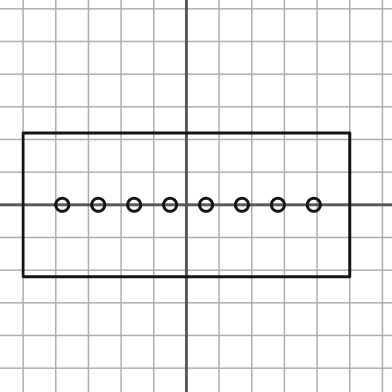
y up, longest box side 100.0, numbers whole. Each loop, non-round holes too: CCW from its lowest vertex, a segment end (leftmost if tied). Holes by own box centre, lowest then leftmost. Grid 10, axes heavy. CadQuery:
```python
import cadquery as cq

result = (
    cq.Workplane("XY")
    .moveTo(-50.0, -22.0)
    .lineTo(50.0, -22.0)
    .lineTo(50.0, 22.0)
    .lineTo(-50.0, 22.0)
    .close()
    .moveTo(-38.0, 0.0)
    .circle(2.0)
    .moveTo(-27.0, 0.0)
    .circle(2.0)
    .moveTo(-16.0, 0.0)
    .circle(2.0)
    .moveTo(-5.0, 0.0)
    .circle(2.0)
    .moveTo(6.0, 0.0)
    .circle(2.0)
    .moveTo(17.0, 0.0)
    .circle(2.0)
    .moveTo(28.0, 0.0)
    .circle(2.0)
    .moveTo(39.0, 0.0)
    .circle(2.0)
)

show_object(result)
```